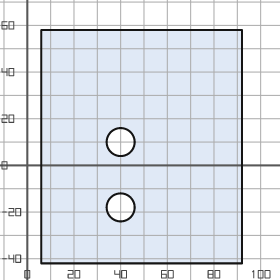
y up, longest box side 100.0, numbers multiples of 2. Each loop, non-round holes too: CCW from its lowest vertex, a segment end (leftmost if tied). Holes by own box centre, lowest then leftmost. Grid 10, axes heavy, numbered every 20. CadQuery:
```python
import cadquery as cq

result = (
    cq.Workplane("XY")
    .moveTo(6.0, -42.0)
    .lineTo(92.0, -42.0)
    .lineTo(92.0, 58.0)
    .lineTo(6.0, 58.0)
    .close()
    .moveTo(40.0, -18.0)
    .circle(6.0)
    .moveTo(40.0, 10.0)
    .circle(6.0)
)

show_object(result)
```